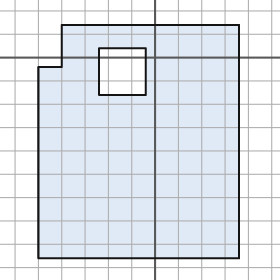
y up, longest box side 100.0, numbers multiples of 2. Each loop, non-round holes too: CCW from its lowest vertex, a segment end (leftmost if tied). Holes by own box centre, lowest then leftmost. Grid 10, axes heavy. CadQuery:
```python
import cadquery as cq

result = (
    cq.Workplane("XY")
    .moveTo(-50.0, -86.0)
    .lineTo(36.0, -86.0)
    .lineTo(36.0, 14.0)
    .lineTo(-40.0, 14.0)
    .lineTo(-40.0, -4.0)
    .lineTo(-50.0, -4.0)
    .close()
    .moveTo(-24.0, -16.0)
    .lineTo(-4.0, -16.0)
    .lineTo(-4.0, 4.0)
    .lineTo(-24.0, 4.0)
    .close()
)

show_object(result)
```